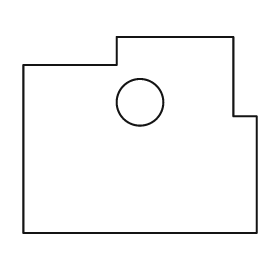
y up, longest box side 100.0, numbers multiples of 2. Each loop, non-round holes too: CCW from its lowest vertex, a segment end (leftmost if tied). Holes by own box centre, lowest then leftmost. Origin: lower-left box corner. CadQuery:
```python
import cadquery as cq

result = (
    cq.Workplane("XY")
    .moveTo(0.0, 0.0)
    .lineTo(100.0, 0.0)
    .lineTo(100.0, 50.0)
    .lineTo(90.0, 50.0)
    .lineTo(90.0, 84.0)
    .lineTo(40.0, 84.0)
    .lineTo(40.0, 72.0)
    .lineTo(0.0, 72.0)
    .close()
    .moveTo(50.0, 56.0)
    .circle(10.0)
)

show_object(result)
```